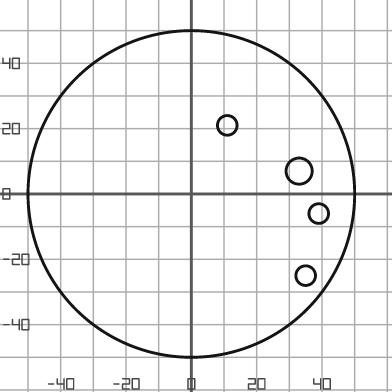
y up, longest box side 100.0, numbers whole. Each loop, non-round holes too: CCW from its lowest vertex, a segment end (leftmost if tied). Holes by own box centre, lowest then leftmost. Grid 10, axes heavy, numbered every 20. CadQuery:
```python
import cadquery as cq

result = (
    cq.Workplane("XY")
    .moveTo(0.0, 0.0)
    .circle(50.0)
    .moveTo(35.0, -25.0)
    .circle(3.0)
    .moveTo(39.0, -6.0)
    .circle(3.0)
    .moveTo(33.0, 7.0)
    .circle(4.0)
    .moveTo(11.0, 21.0)
    .circle(3.0)
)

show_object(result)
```